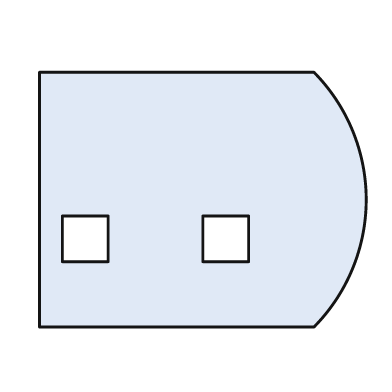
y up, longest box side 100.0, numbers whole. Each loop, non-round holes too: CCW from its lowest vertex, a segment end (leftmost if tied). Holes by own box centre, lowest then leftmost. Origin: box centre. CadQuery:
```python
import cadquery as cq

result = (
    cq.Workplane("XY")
    .moveTo(-50.0, -39.0)
    .lineTo(34.0, -39.0)
    .threePointArc((50.0, 0.0), (34.0, 39.0))
    .lineTo(-50.0, 39.0)
    .close()
    .moveTo(-43.0, -19.0)
    .lineTo(-29.0, -19.0)
    .lineTo(-29.0, -5.0)
    .lineTo(-43.0, -5.0)
    .close()
    .moveTo(0.0, -19.0)
    .lineTo(14.0, -19.0)
    .lineTo(14.0, -5.0)
    .lineTo(0.0, -5.0)
    .close()
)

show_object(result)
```